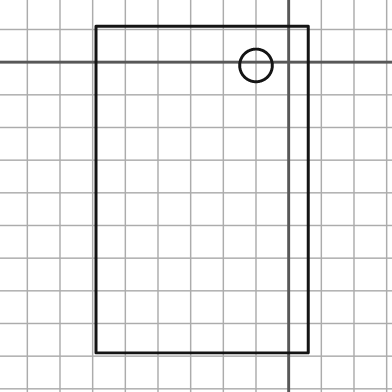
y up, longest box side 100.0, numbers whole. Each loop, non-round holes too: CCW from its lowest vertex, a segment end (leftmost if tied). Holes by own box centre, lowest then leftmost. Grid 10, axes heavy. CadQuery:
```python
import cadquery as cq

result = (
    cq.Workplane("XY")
    .moveTo(-59.0, -89.0)
    .lineTo(6.0, -89.0)
    .lineTo(6.0, 11.0)
    .lineTo(-59.0, 11.0)
    .close()
    .moveTo(-10.0, -1.0)
    .circle(5.0)
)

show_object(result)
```